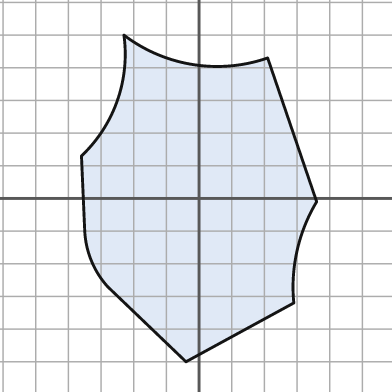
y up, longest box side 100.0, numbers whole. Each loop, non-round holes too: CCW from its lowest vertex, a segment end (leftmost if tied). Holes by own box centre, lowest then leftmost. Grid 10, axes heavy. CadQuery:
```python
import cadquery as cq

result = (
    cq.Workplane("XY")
    .moveTo(-4.0, -50.0)
    .lineTo(29.0, -32.0)
    .threePointArc((30.0, -16.0), (36.0, -1.0))
    .lineTo(21.0, 43.0)
    .threePointArc((-2.0, 41.0), (-23.0, 50.0))
    .threePointArc((-25.0, 30.0), (-36.0, 13.0))
    .lineTo(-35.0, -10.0)
    .threePointArc((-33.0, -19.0), (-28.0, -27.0))
    .close()
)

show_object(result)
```